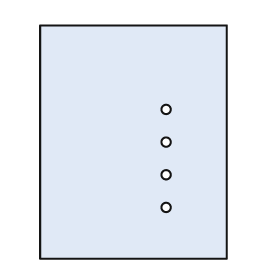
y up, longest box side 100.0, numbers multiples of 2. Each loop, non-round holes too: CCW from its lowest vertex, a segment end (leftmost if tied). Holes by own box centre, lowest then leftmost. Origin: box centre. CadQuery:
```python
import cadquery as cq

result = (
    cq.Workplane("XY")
    .moveTo(-40.0, -50.0)
    .lineTo(40.0, -50.0)
    .lineTo(40.0, 50.0)
    .lineTo(-40.0, 50.0)
    .close()
    .moveTo(14.0, -28.0)
    .circle(2.0)
    .moveTo(14.0, -14.0)
    .circle(2.0)
    .moveTo(14.0, 0.0)
    .circle(2.0)
    .moveTo(14.0, 14.0)
    .circle(2.0)
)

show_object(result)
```